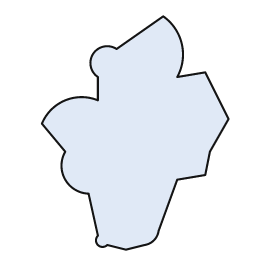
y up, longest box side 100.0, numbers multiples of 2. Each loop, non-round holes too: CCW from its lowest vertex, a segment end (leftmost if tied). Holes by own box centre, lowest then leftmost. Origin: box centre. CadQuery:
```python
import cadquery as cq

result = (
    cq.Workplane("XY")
    .moveTo(-4.0, -50.0)
    .lineTo(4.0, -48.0)
    .threePointArc((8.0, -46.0), (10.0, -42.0))
    .lineTo(18.0, -20.0)
    .lineTo(30.0, -18.0)
    .lineTo(32.0, -8.0)
    .lineTo(40.0, 6.0)
    .lineTo(30.0, 26.0)
    .lineTo(18.0, 24.0)
    .threePointArc((20.0, 38.0), (12.0, 50.0))
    .lineTo(-8.0, 36.0)
    .threePointArc((-18.0, 34.0), (-16.0, 24.0))
    .lineTo(-16.0, 14.0)
    .threePointArc((-30.0, 14.0), (-40.0, 4.0))
    .lineTo(-30.0, -8.0)
    .threePointArc((-30.0, -20.0), (-20.0, -26.0))
    .lineTo(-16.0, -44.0)
    .threePointArc((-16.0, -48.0), (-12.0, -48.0))
    .close()
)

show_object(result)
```